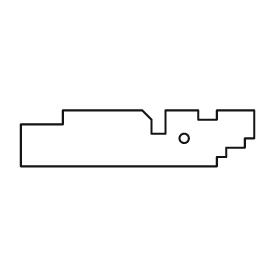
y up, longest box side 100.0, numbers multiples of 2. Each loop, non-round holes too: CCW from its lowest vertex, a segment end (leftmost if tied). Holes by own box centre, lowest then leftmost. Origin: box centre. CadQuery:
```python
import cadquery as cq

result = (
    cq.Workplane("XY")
    .moveTo(-50.0, -12.0)
    .lineTo(34.0, -12.0)
    .lineTo(34.0, -8.0)
    .lineTo(38.0, -8.0)
    .lineTo(38.0, -4.0)
    .lineTo(46.0, -4.0)
    .lineTo(46.0, 0.0)
    .lineTo(50.0, 0.0)
    .lineTo(50.0, 12.0)
    .lineTo(34.0, 12.0)
    .lineTo(34.0, 8.0)
    .lineTo(26.0, 8.0)
    .lineTo(26.0, 12.0)
    .lineTo(12.0, 12.0)
    .lineTo(12.0, 2.0)
    .lineTo(6.0, 2.0)
    .lineTo(6.0, 8.0)
    .lineTo(2.0, 12.0)
    .lineTo(-32.0, 12.0)
    .lineTo(-32.0, 6.0)
    .lineTo(-50.0, 6.0)
    .close()
    .moveTo(20.0, 0.0)
    .circle(2.0)
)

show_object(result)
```